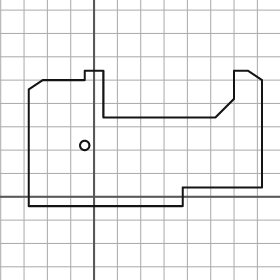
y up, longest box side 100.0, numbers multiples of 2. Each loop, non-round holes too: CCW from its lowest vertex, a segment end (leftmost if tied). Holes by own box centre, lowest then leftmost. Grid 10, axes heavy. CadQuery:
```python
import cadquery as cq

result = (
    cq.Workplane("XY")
    .moveTo(-28.0, -4.0)
    .lineTo(38.0, -4.0)
    .lineTo(38.0, 4.0)
    .lineTo(72.0, 4.0)
    .lineTo(72.0, 50.0)
    .lineTo(66.0, 54.0)
    .lineTo(60.0, 54.0)
    .lineTo(60.0, 42.0)
    .lineTo(52.0, 34.0)
    .lineTo(4.0, 34.0)
    .lineTo(4.0, 54.0)
    .lineTo(-4.0, 54.0)
    .lineTo(-4.0, 50.0)
    .lineTo(-22.0, 50.0)
    .lineTo(-28.0, 46.0)
    .close()
    .moveTo(-4.0, 22.0)
    .circle(2.0)
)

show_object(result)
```